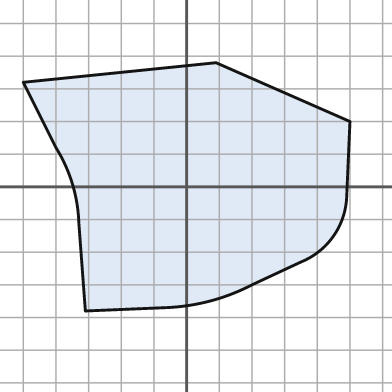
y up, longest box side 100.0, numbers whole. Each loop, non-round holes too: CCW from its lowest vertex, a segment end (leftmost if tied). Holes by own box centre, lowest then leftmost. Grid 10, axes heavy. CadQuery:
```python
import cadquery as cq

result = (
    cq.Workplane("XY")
    .moveTo(-31.0, -38.0)
    .lineTo(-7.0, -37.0)
    .threePointArc((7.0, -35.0), (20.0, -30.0))
    .lineTo(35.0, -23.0)
    .threePointArc((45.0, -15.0), (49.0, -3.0))
    .lineTo(50.0, 20.0)
    .lineTo(9.0, 38.0)
    .lineTo(-50.0, 32.0)
    .lineTo(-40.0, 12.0)
    .threePointArc((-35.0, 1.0), (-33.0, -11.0))
    .close()
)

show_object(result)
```